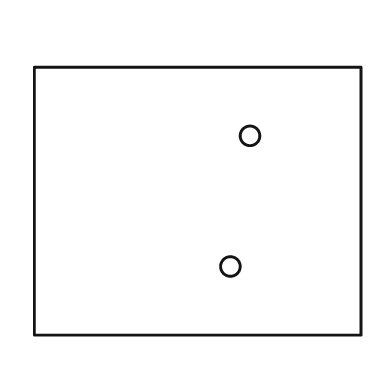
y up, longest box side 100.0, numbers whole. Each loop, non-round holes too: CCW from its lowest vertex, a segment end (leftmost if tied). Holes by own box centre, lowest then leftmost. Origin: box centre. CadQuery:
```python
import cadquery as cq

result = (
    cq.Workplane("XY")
    .moveTo(-50.0, -41.0)
    .lineTo(50.0, -41.0)
    .lineTo(50.0, 41.0)
    .lineTo(-50.0, 41.0)
    .close()
    .moveTo(10.0, -20.0)
    .circle(3.0)
    .moveTo(16.0, 20.0)
    .circle(3.0)
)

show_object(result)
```